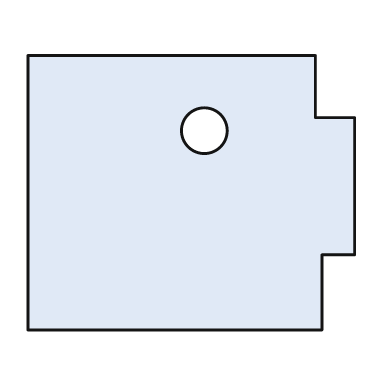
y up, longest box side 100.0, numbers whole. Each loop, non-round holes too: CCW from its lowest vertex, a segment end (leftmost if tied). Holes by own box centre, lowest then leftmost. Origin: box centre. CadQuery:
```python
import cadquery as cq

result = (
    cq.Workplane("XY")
    .moveTo(-50.0, -42.0)
    .lineTo(40.0, -42.0)
    .lineTo(40.0, -19.0)
    .lineTo(50.0, -19.0)
    .lineTo(50.0, 23.0)
    .lineTo(38.0, 23.0)
    .lineTo(38.0, 42.0)
    .lineTo(-50.0, 42.0)
    .close()
    .moveTo(4.0, 19.0)
    .circle(7.0)
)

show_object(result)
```